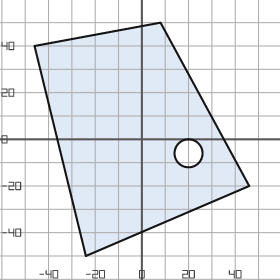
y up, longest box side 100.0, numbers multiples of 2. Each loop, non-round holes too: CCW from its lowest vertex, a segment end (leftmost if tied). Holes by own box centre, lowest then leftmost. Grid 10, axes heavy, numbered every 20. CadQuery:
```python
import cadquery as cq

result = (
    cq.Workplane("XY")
    .moveTo(-24.0, -50.0)
    .lineTo(46.0, -20.0)
    .lineTo(8.0, 50.0)
    .lineTo(-46.0, 40.0)
    .close()
    .moveTo(20.0, -6.0)
    .circle(6.0)
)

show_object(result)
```